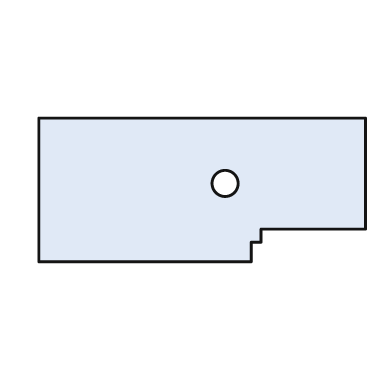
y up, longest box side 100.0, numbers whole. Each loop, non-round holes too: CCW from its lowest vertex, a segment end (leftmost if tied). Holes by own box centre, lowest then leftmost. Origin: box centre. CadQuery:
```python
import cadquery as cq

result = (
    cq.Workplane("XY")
    .moveTo(-50.0, -22.0)
    .lineTo(15.0, -22.0)
    .lineTo(15.0, -16.0)
    .lineTo(18.0, -16.0)
    .lineTo(18.0, -12.0)
    .lineTo(50.0, -12.0)
    .lineTo(50.0, 22.0)
    .lineTo(-50.0, 22.0)
    .close()
    .moveTo(7.0, 2.0)
    .circle(4.0)
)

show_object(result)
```